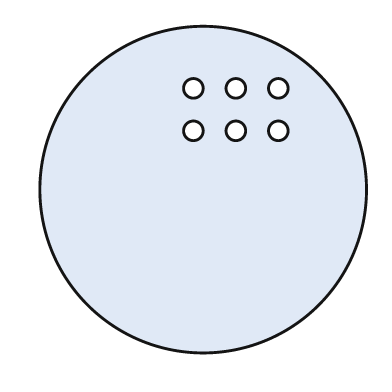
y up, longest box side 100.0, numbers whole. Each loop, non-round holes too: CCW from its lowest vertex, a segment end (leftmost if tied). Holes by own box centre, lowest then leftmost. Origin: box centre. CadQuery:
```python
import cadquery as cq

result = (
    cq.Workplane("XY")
    .moveTo(0.0, 0.0)
    .circle(50.0)
    .moveTo(-3.0, 18.0)
    .circle(3.0)
    .moveTo(10.0, 18.0)
    .circle(3.0)
    .moveTo(23.0, 18.0)
    .circle(3.0)
    .moveTo(-3.0, 31.0)
    .circle(3.0)
    .moveTo(10.0, 31.0)
    .circle(3.0)
    .moveTo(23.0, 31.0)
    .circle(3.0)
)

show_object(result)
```